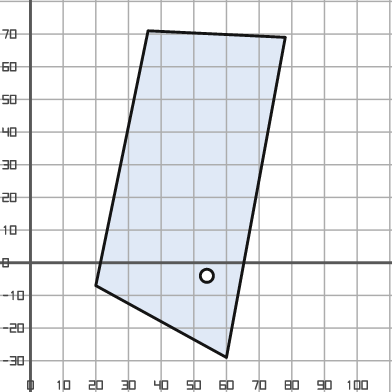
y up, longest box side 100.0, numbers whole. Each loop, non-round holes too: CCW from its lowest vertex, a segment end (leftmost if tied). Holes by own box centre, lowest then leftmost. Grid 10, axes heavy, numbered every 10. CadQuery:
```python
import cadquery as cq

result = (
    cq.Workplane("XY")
    .moveTo(60.0, -29.0)
    .lineTo(78.0, 69.0)
    .lineTo(36.0, 71.0)
    .lineTo(20.0, -7.0)
    .close()
    .moveTo(54.0, -4.0)
    .circle(2.0)
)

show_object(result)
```